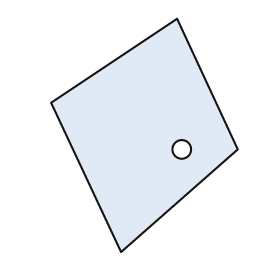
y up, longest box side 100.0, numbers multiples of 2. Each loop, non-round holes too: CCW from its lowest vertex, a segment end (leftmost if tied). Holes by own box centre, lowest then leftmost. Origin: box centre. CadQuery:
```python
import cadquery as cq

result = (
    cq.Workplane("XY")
    .moveTo(-10.0, -50.0)
    .lineTo(40.0, -6.0)
    .lineTo(14.0, 50.0)
    .lineTo(-40.0, 14.0)
    .close()
    .moveTo(16.0, -6.0)
    .circle(4.0)
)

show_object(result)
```